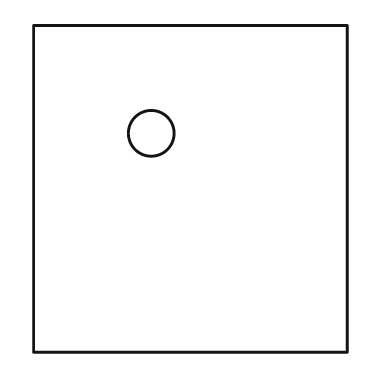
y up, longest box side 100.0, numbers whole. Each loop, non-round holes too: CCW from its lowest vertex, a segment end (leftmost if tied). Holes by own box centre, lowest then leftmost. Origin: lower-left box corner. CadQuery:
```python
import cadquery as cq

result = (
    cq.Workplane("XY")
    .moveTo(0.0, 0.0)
    .lineTo(96.0, 0.0)
    .lineTo(96.0, 100.0)
    .lineTo(0.0, 100.0)
    .close()
    .moveTo(36.0, 67.0)
    .circle(7.0)
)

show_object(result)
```